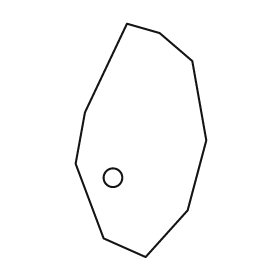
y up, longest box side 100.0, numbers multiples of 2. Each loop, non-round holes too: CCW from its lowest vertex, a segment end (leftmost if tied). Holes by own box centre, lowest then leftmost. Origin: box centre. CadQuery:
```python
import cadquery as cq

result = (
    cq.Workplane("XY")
    .moveTo(2.0, -50.0)
    .lineTo(20.0, -30.0)
    .lineTo(28.0, 0.0)
    .lineTo(22.0, 34.0)
    .lineTo(8.0, 46.0)
    .lineTo(-6.0, 50.0)
    .lineTo(-24.0, 12.0)
    .lineTo(-28.0, -10.0)
    .lineTo(-16.0, -42.0)
    .close()
    .moveTo(-12.0, -16.0)
    .circle(4.0)
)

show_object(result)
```